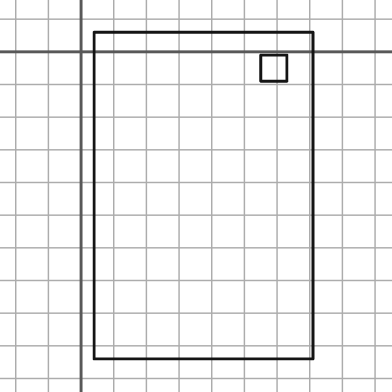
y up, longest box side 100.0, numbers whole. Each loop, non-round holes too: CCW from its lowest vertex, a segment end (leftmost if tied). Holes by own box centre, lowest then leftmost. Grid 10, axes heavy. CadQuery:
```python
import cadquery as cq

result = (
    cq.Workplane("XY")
    .moveTo(4.0, -94.0)
    .lineTo(71.0, -94.0)
    .lineTo(71.0, 6.0)
    .lineTo(4.0, 6.0)
    .close()
    .moveTo(55.0, -9.0)
    .lineTo(63.0, -9.0)
    .lineTo(63.0, -1.0)
    .lineTo(55.0, -1.0)
    .close()
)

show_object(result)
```